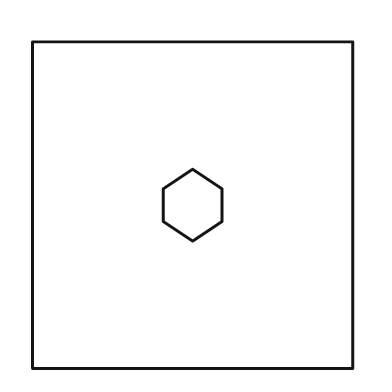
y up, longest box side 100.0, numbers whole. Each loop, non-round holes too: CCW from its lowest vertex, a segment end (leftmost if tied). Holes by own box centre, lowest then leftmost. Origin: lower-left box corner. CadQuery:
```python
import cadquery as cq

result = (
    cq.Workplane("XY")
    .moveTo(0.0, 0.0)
    .lineTo(98.0, 0.0)
    .lineTo(98.0, 100.0)
    .lineTo(0.0, 100.0)
    .close()
    .moveTo(49.0, 39.0)
    .lineTo(58.0, 45.0)
    .lineTo(58.0, 55.0)
    .lineTo(49.0, 61.0)
    .lineTo(40.0, 55.0)
    .lineTo(40.0, 45.0)
    .close()
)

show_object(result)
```